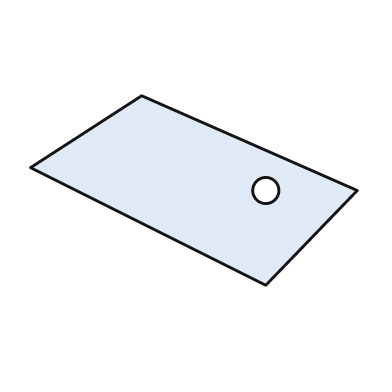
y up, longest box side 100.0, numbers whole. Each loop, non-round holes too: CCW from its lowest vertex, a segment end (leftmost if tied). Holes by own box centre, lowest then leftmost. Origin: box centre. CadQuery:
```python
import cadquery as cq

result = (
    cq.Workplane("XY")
    .moveTo(22.0, -29.0)
    .lineTo(50.0, 0.0)
    .lineTo(-16.0, 29.0)
    .lineTo(-50.0, 7.0)
    .close()
    .moveTo(22.0, 0.0)
    .circle(4.0)
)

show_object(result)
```